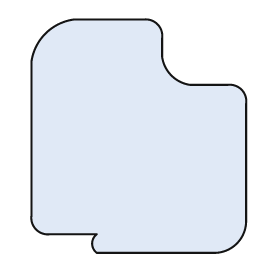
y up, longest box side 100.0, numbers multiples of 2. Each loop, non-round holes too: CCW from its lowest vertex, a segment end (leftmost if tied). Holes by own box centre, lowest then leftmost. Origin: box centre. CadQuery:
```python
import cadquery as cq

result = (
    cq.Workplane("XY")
    .moveTo(-18.0, -50.0)
    .lineTo(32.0, -50.0)
    .threePointArc((42.0, -46.0), (46.0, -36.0))
    .lineTo(46.0, 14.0)
    .threePointArc((44.0, 20.0), (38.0, 22.0))
    .lineTo(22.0, 22.0)
    .threePointArc((14.0, 26.0), (10.0, 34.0))
    .lineTo(10.0, 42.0)
    .threePointArc((8.0, 48.0), (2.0, 50.0))
    .lineTo(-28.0, 50.0)
    .threePointArc((-40.0, 44.0), (-46.0, 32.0))
    .lineTo(-46.0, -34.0)
    .threePointArc((-44.0, -40.0), (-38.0, -42.0))
    .lineTo(-18.0, -42.0)
    .threePointArc((-20.0, -46.0), (-18.0, -50.0))
    .close()
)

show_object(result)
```